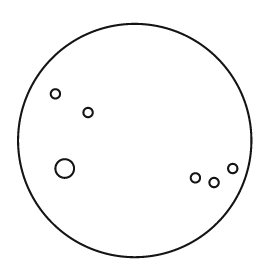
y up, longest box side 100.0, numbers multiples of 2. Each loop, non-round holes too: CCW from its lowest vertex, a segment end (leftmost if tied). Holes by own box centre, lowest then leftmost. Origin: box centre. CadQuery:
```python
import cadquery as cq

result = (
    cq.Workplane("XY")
    .moveTo(0.0, 0.0)
    .circle(50.0)
    .moveTo(34.0, -18.0)
    .circle(2.0)
    .moveTo(26.0, -16.0)
    .circle(2.0)
    .moveTo(-30.0, -12.0)
    .circle(4.0)
    .moveTo(42.0, -12.0)
    .circle(2.0)
    .moveTo(-20.0, 12.0)
    .circle(2.0)
    .moveTo(-34.0, 20.0)
    .circle(2.0)
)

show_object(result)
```